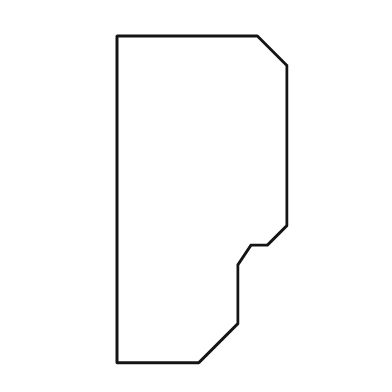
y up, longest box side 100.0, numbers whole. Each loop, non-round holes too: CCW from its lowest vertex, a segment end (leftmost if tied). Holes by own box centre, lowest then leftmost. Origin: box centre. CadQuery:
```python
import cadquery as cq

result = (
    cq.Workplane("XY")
    .moveTo(-26.0, -50.0)
    .lineTo(-1.0, -50.0)
    .lineTo(11.0, -38.0)
    .lineTo(11.0, -20.0)
    .lineTo(15.0, -14.0)
    .lineTo(20.0, -14.0)
    .lineTo(26.0, -8.0)
    .lineTo(26.0, 41.0)
    .lineTo(17.0, 50.0)
    .lineTo(-26.0, 50.0)
    .close()
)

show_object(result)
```